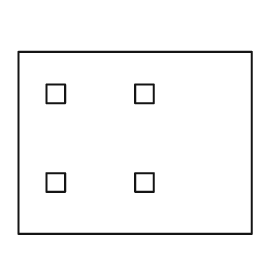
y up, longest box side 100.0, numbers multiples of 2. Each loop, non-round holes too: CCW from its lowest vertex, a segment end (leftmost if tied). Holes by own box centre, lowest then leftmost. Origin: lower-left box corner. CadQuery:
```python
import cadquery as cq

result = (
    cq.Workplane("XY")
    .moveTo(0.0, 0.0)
    .lineTo(100.0, 0.0)
    .lineTo(100.0, 78.0)
    .lineTo(0.0, 78.0)
    .close()
    .moveTo(12.0, 18.0)
    .lineTo(20.0, 18.0)
    .lineTo(20.0, 26.0)
    .lineTo(12.0, 26.0)
    .close()
    .moveTo(50.0, 18.0)
    .lineTo(58.0, 18.0)
    .lineTo(58.0, 26.0)
    .lineTo(50.0, 26.0)
    .close()
    .moveTo(12.0, 56.0)
    .lineTo(20.0, 56.0)
    .lineTo(20.0, 64.0)
    .lineTo(12.0, 64.0)
    .close()
    .moveTo(50.0, 56.0)
    .lineTo(58.0, 56.0)
    .lineTo(58.0, 64.0)
    .lineTo(50.0, 64.0)
    .close()
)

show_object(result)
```